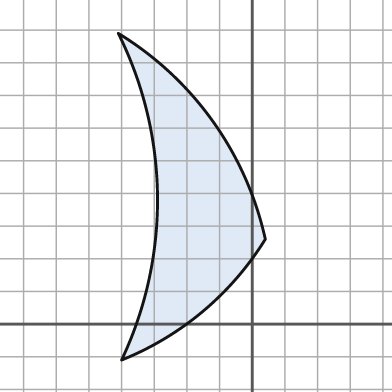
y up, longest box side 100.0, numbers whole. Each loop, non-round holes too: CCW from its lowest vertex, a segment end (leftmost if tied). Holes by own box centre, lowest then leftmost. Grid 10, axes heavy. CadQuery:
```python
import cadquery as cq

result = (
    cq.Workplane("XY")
    .moveTo(-40.0, -11.0)
    .threePointArc((-15.0, 4.0), (4.0, 26.0))
    .threePointArc((-12.0, 62.0), (-41.0, 89.0))
    .threePointArc((-29.0, 39.0), (-40.0, -11.0))
    .close()
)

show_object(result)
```